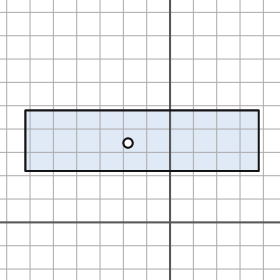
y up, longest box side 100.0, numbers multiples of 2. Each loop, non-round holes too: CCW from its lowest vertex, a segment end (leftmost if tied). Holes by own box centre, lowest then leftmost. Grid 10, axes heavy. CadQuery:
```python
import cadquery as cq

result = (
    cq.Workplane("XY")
    .moveTo(-62.0, 22.0)
    .lineTo(38.0, 22.0)
    .lineTo(38.0, 48.0)
    .lineTo(-62.0, 48.0)
    .close()
    .moveTo(-18.0, 34.0)
    .circle(2.0)
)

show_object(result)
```